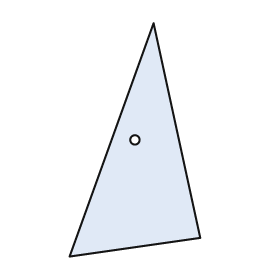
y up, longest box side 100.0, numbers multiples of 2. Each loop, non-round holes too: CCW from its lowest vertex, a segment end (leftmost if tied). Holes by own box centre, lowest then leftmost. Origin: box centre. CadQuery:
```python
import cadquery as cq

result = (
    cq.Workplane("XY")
    .moveTo(-28.0, -50.0)
    .lineTo(28.0, -42.0)
    .lineTo(8.0, 50.0)
    .close()
    .moveTo(0.0, 0.0)
    .circle(2.0)
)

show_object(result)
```